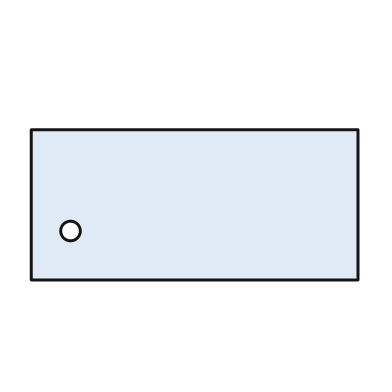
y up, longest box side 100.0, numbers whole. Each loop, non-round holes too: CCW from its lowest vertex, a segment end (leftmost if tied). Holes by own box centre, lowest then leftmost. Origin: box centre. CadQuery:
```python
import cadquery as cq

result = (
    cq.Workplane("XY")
    .moveTo(-50.0, -23.0)
    .lineTo(50.0, -23.0)
    .lineTo(50.0, 23.0)
    .lineTo(-50.0, 23.0)
    .close()
    .moveTo(-38.0, -8.0)
    .circle(3.0)
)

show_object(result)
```